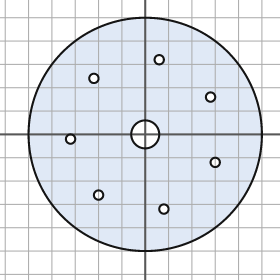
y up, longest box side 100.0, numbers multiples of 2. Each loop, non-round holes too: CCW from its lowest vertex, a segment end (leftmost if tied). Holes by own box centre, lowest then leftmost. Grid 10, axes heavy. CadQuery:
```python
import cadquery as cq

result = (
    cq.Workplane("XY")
    .moveTo(0.0, 0.0)
    .circle(50.0)
    .moveTo(8.0, -32.0)
    .circle(2.0)
    .moveTo(-20.0, -26.0)
    .circle(2.0)
    .moveTo(30.0, -12.0)
    .circle(2.0)
    .moveTo(-32.0, -2.0)
    .circle(2.0)
    .moveTo(0.0, 0.0)
    .circle(6.0)
    .moveTo(28.0, 16.0)
    .circle(2.0)
    .moveTo(-22.0, 24.0)
    .circle(2.0)
    .moveTo(6.0, 32.0)
    .circle(2.0)
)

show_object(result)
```